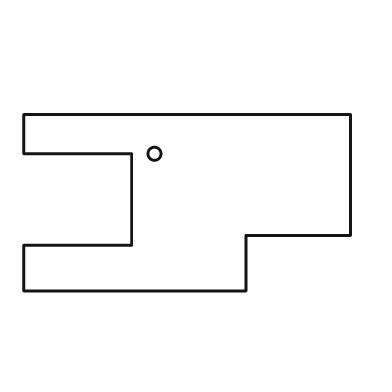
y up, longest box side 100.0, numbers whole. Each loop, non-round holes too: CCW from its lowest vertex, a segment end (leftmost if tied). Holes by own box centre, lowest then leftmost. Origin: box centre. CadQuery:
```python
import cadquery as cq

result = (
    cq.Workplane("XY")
    .moveTo(-50.0, -27.0)
    .lineTo(18.0, -27.0)
    .lineTo(18.0, -10.0)
    .lineTo(50.0, -10.0)
    .lineTo(50.0, 27.0)
    .lineTo(-50.0, 27.0)
    .lineTo(-50.0, 15.0)
    .lineTo(-17.0, 15.0)
    .lineTo(-17.0, -13.0)
    .lineTo(-50.0, -13.0)
    .close()
    .moveTo(-10.0, 15.0)
    .circle(2.0)
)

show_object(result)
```